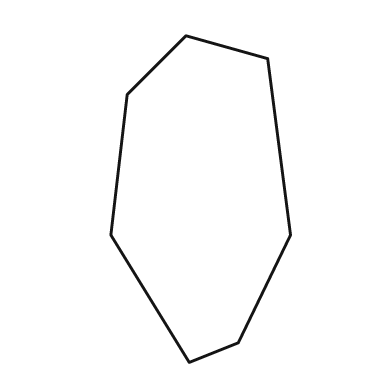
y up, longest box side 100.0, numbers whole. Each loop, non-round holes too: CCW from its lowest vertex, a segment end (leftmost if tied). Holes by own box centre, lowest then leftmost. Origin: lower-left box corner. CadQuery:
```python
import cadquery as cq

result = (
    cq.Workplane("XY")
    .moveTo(24.0, 0.0)
    .lineTo(39.0, 6.0)
    .lineTo(55.0, 39.0)
    .lineTo(48.0, 93.0)
    .lineTo(23.0, 100.0)
    .lineTo(5.0, 82.0)
    .lineTo(0.0, 39.0)
    .close()
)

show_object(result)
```